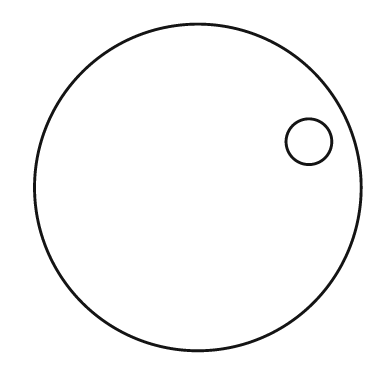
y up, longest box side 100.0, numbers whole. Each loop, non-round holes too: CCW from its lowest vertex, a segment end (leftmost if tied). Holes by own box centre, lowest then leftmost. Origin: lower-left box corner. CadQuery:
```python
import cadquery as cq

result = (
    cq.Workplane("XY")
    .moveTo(50.0, 50.0)
    .circle(50.0)
    .moveTo(84.0, 64.0)
    .circle(7.0)
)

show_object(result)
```